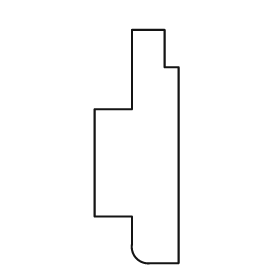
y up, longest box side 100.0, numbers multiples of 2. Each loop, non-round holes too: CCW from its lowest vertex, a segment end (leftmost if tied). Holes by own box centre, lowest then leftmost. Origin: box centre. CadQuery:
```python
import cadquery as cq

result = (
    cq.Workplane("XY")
    .moveTo(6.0, -50.0)
    .lineTo(18.0, -50.0)
    .lineTo(18.0, 34.0)
    .lineTo(12.0, 34.0)
    .lineTo(12.0, 50.0)
    .lineTo(-2.0, 50.0)
    .lineTo(-2.0, 16.0)
    .lineTo(-18.0, 16.0)
    .lineTo(-18.0, -30.0)
    .lineTo(-2.0, -30.0)
    .lineTo(-2.0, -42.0)
    .threePointArc((0.0, -48.0), (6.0, -50.0))
    .close()
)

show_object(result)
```